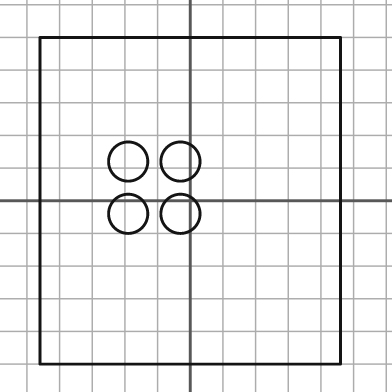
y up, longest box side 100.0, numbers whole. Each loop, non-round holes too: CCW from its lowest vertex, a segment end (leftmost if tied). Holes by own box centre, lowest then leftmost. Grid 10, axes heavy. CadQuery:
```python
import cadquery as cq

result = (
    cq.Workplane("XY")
    .moveTo(-46.0, -50.0)
    .lineTo(46.0, -50.0)
    .lineTo(46.0, 50.0)
    .lineTo(-46.0, 50.0)
    .close()
    .moveTo(-19.0, -4.0)
    .circle(6.0)
    .moveTo(-3.0, -4.0)
    .circle(6.0)
    .moveTo(-19.0, 12.0)
    .circle(6.0)
    .moveTo(-3.0, 12.0)
    .circle(6.0)
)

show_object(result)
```